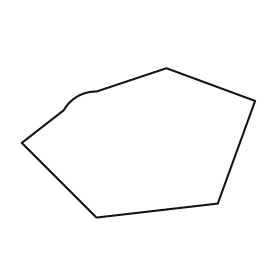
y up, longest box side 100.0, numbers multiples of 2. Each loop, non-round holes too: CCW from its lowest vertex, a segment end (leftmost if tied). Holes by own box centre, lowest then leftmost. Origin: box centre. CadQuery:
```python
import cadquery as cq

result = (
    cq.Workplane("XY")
    .moveTo(-18.0, -32.0)
    .lineTo(34.0, -26.0)
    .lineTo(50.0, 18.0)
    .lineTo(12.0, 32.0)
    .lineTo(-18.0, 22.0)
    .threePointArc((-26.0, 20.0), (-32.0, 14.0))
    .lineTo(-50.0, 0.0)
    .close()
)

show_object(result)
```